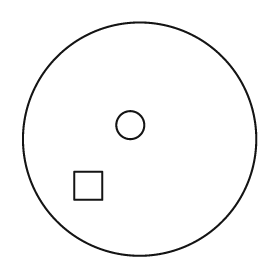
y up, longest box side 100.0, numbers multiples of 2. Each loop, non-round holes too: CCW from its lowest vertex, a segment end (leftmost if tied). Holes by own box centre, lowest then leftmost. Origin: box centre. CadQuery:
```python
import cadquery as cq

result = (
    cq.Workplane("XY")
    .moveTo(0.0, 0.0)
    .circle(50.0)
    .moveTo(-28.0, -26.0)
    .lineTo(-16.0, -26.0)
    .lineTo(-16.0, -14.0)
    .lineTo(-28.0, -14.0)
    .close()
    .moveTo(-4.0, 6.0)
    .circle(6.0)
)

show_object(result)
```